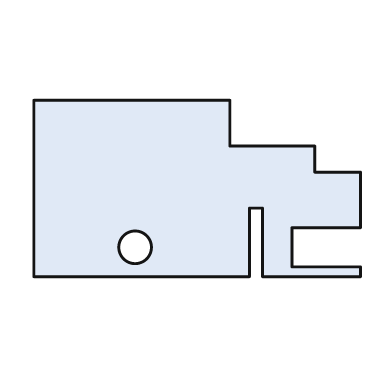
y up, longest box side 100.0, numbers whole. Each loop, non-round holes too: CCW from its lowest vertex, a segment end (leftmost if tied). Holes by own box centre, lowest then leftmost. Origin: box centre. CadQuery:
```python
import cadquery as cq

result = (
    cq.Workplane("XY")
    .moveTo(-50.0, -27.0)
    .lineTo(16.0, -27.0)
    .lineTo(16.0, -6.0)
    .lineTo(20.0, -6.0)
    .lineTo(20.0, -27.0)
    .lineTo(50.0, -27.0)
    .lineTo(50.0, -24.0)
    .lineTo(29.0, -24.0)
    .lineTo(29.0, -12.0)
    .lineTo(50.0, -12.0)
    .lineTo(50.0, 5.0)
    .lineTo(36.0, 5.0)
    .lineTo(36.0, 13.0)
    .lineTo(10.0, 13.0)
    .lineTo(10.0, 27.0)
    .lineTo(-50.0, 27.0)
    .close()
    .moveTo(-19.0, -18.0)
    .circle(5.0)
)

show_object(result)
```